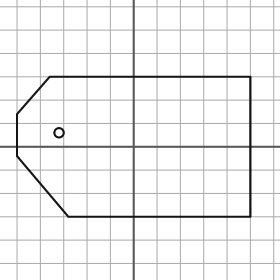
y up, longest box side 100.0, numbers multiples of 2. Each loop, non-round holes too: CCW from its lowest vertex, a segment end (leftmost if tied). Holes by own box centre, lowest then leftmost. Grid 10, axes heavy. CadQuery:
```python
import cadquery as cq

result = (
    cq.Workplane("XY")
    .moveTo(-28.0, -30.0)
    .lineTo(50.0, -30.0)
    .lineTo(50.0, 30.0)
    .lineTo(-36.0, 30.0)
    .lineTo(-50.0, 14.0)
    .lineTo(-50.0, -4.0)
    .close()
    .moveTo(-32.0, 6.0)
    .circle(2.0)
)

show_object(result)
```